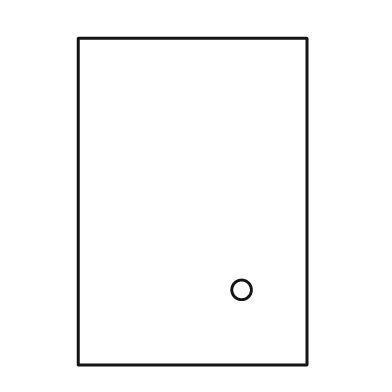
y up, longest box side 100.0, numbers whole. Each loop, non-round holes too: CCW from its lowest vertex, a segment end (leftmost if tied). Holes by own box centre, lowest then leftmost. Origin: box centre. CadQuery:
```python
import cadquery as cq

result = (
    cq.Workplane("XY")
    .moveTo(-35.0, -50.0)
    .lineTo(35.0, -50.0)
    .lineTo(35.0, 50.0)
    .lineTo(-35.0, 50.0)
    .close()
    .moveTo(15.0, -27.0)
    .circle(3.0)
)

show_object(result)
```